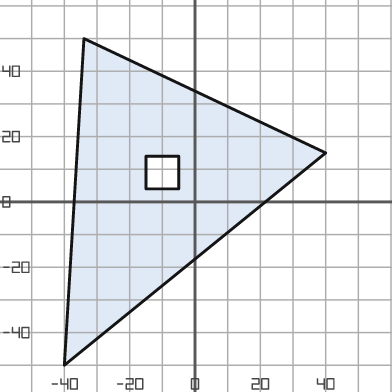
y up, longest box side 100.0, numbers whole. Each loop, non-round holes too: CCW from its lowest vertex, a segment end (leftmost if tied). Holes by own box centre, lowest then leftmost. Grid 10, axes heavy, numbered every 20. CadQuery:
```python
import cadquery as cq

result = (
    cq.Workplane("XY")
    .moveTo(-40.0, -50.0)
    .lineTo(40.0, 15.0)
    .lineTo(-34.0, 50.0)
    .close()
    .moveTo(-15.0, 4.0)
    .lineTo(-5.0, 4.0)
    .lineTo(-5.0, 14.0)
    .lineTo(-15.0, 14.0)
    .close()
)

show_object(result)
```